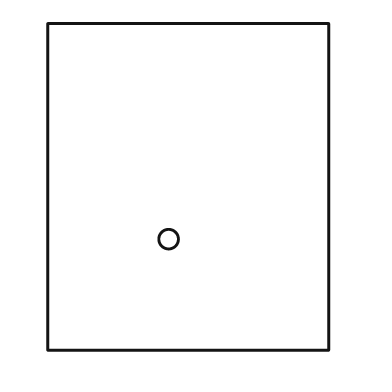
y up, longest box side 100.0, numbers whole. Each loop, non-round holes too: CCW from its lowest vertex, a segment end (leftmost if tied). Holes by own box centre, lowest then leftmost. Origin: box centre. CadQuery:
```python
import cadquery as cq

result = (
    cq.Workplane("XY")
    .moveTo(-43.0, -50.0)
    .lineTo(43.0, -50.0)
    .lineTo(43.0, 50.0)
    .lineTo(-43.0, 50.0)
    .close()
    .moveTo(-6.0, -16.0)
    .circle(3.0)
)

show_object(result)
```